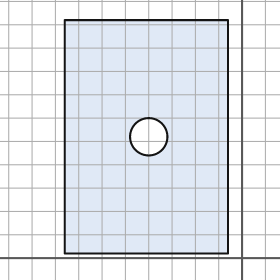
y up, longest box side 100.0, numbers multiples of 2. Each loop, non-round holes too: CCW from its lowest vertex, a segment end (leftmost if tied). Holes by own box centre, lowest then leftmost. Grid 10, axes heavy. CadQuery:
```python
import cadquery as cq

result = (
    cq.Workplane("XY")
    .moveTo(-76.0, 2.0)
    .lineTo(-6.0, 2.0)
    .lineTo(-6.0, 102.0)
    .lineTo(-76.0, 102.0)
    .close()
    .moveTo(-40.0, 52.0)
    .circle(8.0)
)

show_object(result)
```